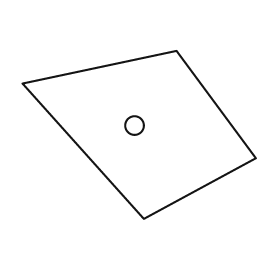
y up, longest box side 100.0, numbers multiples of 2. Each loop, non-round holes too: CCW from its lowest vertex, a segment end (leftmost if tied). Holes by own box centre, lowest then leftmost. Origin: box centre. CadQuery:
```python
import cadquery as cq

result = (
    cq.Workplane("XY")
    .moveTo(2.0, -36.0)
    .lineTo(50.0, -10.0)
    .lineTo(16.0, 36.0)
    .lineTo(-50.0, 22.0)
    .close()
    .moveTo(-2.0, 4.0)
    .circle(4.0)
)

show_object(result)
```